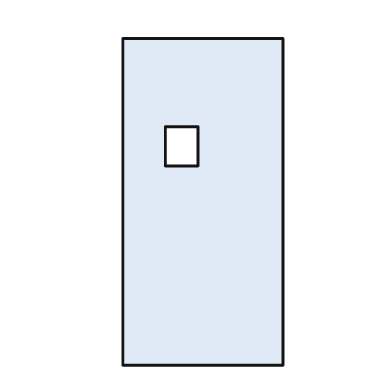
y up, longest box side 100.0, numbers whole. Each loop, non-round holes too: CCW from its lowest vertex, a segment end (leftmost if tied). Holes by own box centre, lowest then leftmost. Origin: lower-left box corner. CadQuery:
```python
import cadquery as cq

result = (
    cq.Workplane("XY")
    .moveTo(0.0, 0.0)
    .lineTo(49.0, 0.0)
    .lineTo(49.0, 100.0)
    .lineTo(0.0, 100.0)
    .close()
    .moveTo(13.0, 61.0)
    .lineTo(23.0, 61.0)
    .lineTo(23.0, 73.0)
    .lineTo(13.0, 73.0)
    .close()
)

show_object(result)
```